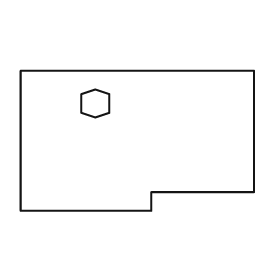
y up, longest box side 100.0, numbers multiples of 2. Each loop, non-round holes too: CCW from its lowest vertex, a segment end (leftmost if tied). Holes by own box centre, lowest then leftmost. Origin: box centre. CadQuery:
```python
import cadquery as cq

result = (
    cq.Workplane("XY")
    .moveTo(-50.0, -30.0)
    .lineTo(6.0, -30.0)
    .lineTo(6.0, -22.0)
    .lineTo(50.0, -22.0)
    .lineTo(50.0, 30.0)
    .lineTo(-50.0, 30.0)
    .close()
    .moveTo(-18.0, 10.0)
    .lineTo(-12.0, 12.0)
    .lineTo(-12.0, 20.0)
    .lineTo(-18.0, 22.0)
    .lineTo(-24.0, 20.0)
    .lineTo(-24.0, 12.0)
    .close()
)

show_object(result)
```